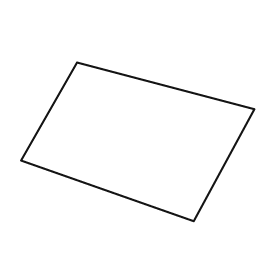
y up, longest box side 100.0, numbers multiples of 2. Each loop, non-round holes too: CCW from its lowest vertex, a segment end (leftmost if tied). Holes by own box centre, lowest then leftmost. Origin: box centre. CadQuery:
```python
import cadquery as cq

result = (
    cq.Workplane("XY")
    .moveTo(24.0, -34.0)
    .lineTo(50.0, 14.0)
    .lineTo(-26.0, 34.0)
    .lineTo(-50.0, -8.0)
    .close()
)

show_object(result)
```